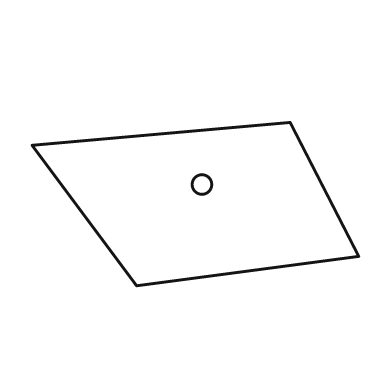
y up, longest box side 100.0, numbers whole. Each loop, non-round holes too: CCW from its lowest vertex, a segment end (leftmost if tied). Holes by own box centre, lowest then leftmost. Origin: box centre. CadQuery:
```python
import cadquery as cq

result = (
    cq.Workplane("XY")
    .moveTo(-18.0, -25.0)
    .lineTo(50.0, -16.0)
    .lineTo(29.0, 25.0)
    .lineTo(-50.0, 18.0)
    .close()
    .moveTo(2.0, 6.0)
    .circle(3.0)
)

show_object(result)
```